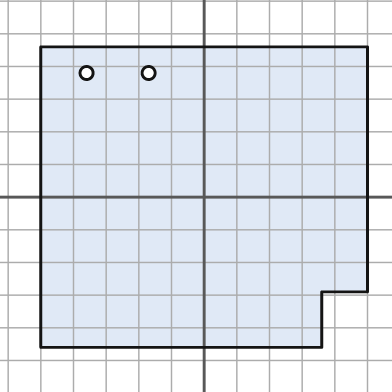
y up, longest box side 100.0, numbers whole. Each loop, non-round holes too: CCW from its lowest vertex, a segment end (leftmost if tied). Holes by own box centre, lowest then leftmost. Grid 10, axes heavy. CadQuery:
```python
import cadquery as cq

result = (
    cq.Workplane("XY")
    .moveTo(-50.0, -46.0)
    .lineTo(36.0, -46.0)
    .lineTo(36.0, -29.0)
    .lineTo(50.0, -29.0)
    .lineTo(50.0, 46.0)
    .lineTo(-50.0, 46.0)
    .close()
    .moveTo(-36.0, 38.0)
    .circle(2.0)
    .moveTo(-17.0, 38.0)
    .circle(2.0)
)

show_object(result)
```